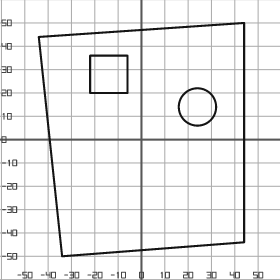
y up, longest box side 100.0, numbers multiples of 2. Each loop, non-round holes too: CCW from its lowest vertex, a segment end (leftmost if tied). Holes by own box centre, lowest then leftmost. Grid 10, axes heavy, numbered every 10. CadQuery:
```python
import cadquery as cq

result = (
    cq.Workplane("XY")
    .moveTo(-34.0, -50.0)
    .lineTo(44.0, -44.0)
    .lineTo(44.0, 50.0)
    .lineTo(-44.0, 44.0)
    .close()
    .moveTo(24.0, 14.0)
    .circle(8.0)
    .moveTo(-22.0, 20.0)
    .lineTo(-6.0, 20.0)
    .lineTo(-6.0, 36.0)
    .lineTo(-22.0, 36.0)
    .close()
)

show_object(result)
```